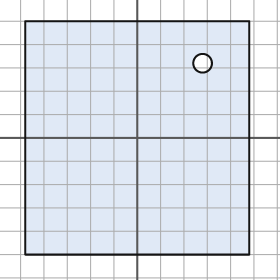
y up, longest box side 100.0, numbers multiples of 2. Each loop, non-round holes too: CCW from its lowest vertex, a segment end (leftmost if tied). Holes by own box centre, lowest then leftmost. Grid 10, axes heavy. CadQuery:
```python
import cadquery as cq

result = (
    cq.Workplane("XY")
    .moveTo(-48.0, -50.0)
    .lineTo(48.0, -50.0)
    .lineTo(48.0, 50.0)
    .lineTo(-48.0, 50.0)
    .close()
    .moveTo(28.0, 32.0)
    .circle(4.0)
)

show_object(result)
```